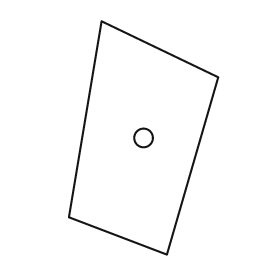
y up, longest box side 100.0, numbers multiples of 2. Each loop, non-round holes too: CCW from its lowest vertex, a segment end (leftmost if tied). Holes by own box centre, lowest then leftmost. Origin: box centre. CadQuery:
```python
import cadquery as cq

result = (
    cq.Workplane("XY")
    .moveTo(10.0, -50.0)
    .lineTo(32.0, 26.0)
    .lineTo(-18.0, 50.0)
    .lineTo(-32.0, -34.0)
    .close()
    .moveTo(0.0, 0.0)
    .circle(4.0)
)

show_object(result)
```